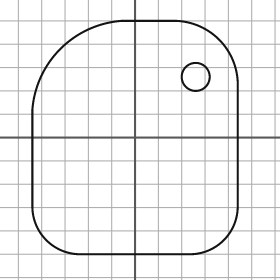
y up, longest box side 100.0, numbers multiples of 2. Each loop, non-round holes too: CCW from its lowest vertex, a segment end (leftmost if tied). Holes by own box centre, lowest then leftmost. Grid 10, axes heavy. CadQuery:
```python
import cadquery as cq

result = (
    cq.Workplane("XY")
    .moveTo(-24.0, -50.0)
    .lineTo(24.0, -50.0)
    .threePointArc((38.0, -44.0), (44.0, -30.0))
    .lineTo(44.0, 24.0)
    .threePointArc((36.0, 42.0), (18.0, 50.0))
    .lineTo(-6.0, 50.0)
    .threePointArc((-32.0, 38.0), (-44.0, 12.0))
    .lineTo(-44.0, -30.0)
    .threePointArc((-38.0, -44.0), (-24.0, -50.0))
    .close()
    .moveTo(26.0, 26.0)
    .circle(6.0)
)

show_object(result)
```